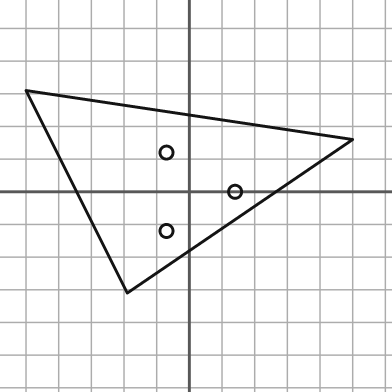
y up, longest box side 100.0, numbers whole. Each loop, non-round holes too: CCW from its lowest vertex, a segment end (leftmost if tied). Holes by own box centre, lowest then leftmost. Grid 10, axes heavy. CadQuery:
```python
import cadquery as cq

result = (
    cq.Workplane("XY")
    .moveTo(-19.0, -31.0)
    .lineTo(50.0, 16.0)
    .lineTo(-50.0, 31.0)
    .close()
    .moveTo(-7.0, -12.0)
    .circle(2.0)
    .moveTo(14.0, 0.0)
    .circle(2.0)
    .moveTo(-7.0, 12.0)
    .circle(2.0)
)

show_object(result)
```